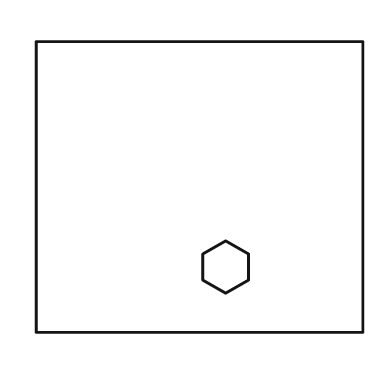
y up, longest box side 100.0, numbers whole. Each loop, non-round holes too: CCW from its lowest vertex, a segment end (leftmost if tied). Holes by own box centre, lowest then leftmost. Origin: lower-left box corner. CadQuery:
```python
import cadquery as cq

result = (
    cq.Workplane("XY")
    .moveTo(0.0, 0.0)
    .lineTo(100.0, 0.0)
    .lineTo(100.0, 89.0)
    .lineTo(0.0, 89.0)
    .close()
    .moveTo(58.0, 12.0)
    .lineTo(65.0, 16.0)
    .lineTo(65.0, 24.0)
    .lineTo(58.0, 28.0)
    .lineTo(51.0, 24.0)
    .lineTo(51.0, 16.0)
    .close()
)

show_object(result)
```